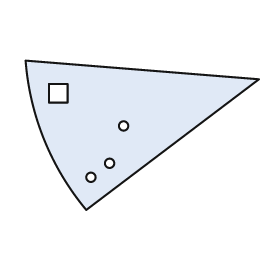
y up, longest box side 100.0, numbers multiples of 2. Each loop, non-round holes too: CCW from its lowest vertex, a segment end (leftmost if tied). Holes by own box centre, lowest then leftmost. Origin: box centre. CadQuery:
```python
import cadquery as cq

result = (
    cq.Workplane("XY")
    .moveTo(-24.0, -32.0)
    .lineTo(50.0, 24.0)
    .lineTo(-50.0, 32.0)
    .threePointArc((-42.0, -2.0), (-24.0, -32.0))
    .close()
    .moveTo(-22.0, -18.0)
    .circle(2.0)
    .moveTo(-14.0, -12.0)
    .circle(2.0)
    .moveTo(-8.0, 4.0)
    .circle(2.0)
    .moveTo(-40.0, 14.0)
    .lineTo(-32.0, 14.0)
    .lineTo(-32.0, 22.0)
    .lineTo(-40.0, 22.0)
    .close()
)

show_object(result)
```